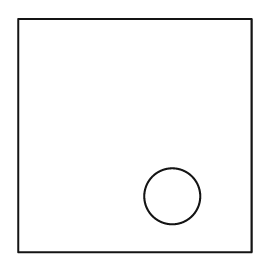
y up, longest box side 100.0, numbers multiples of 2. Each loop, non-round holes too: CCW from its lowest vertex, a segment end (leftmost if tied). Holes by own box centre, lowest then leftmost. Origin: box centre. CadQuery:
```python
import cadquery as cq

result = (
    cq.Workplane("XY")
    .moveTo(-50.0, -50.0)
    .lineTo(50.0, -50.0)
    .lineTo(50.0, 50.0)
    .lineTo(-50.0, 50.0)
    .close()
    .moveTo(16.0, -26.0)
    .circle(12.0)
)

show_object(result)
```